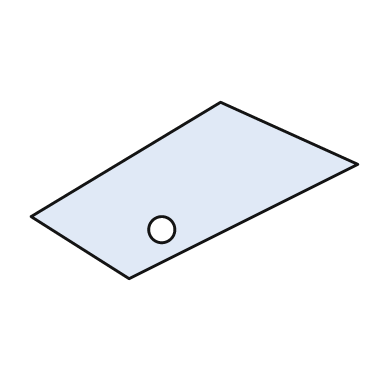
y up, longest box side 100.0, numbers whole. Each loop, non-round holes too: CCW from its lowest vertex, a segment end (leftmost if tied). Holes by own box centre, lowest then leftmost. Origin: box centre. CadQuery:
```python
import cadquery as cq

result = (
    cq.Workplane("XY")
    .moveTo(-20.0, -27.0)
    .lineTo(50.0, 8.0)
    .lineTo(8.0, 27.0)
    .lineTo(-50.0, -8.0)
    .close()
    .moveTo(-10.0, -12.0)
    .circle(4.0)
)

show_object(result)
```